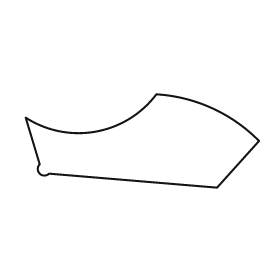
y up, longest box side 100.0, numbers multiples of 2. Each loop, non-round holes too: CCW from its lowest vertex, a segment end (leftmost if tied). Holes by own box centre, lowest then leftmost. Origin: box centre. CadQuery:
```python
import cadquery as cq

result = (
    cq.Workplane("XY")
    .moveTo(32.0, -20.0)
    .lineTo(50.0, 0.0)
    .threePointArc((30.0, 14.0), (6.0, 20.0))
    .threePointArc((-20.0, 4.0), (-50.0, 10.0))
    .lineTo(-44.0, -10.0)
    .threePointArc((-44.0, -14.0), (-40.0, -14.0))
    .close()
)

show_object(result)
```